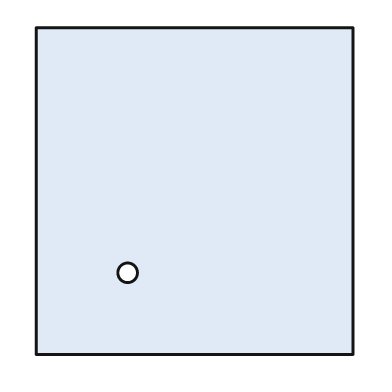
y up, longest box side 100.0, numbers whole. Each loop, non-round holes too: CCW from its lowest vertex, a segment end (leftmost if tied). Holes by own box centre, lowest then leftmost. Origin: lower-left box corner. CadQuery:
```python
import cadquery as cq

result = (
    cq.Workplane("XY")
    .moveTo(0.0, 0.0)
    .lineTo(97.0, 0.0)
    .lineTo(97.0, 100.0)
    .lineTo(0.0, 100.0)
    .close()
    .moveTo(28.0, 25.0)
    .circle(3.0)
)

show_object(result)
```